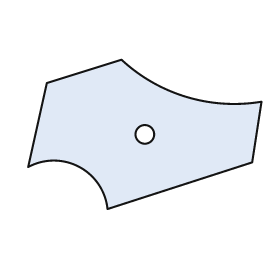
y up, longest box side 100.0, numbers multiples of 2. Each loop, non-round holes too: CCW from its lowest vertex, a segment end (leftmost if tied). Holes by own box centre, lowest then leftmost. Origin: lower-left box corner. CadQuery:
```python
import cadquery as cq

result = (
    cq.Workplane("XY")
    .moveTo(34.0, 0.0)
    .lineTo(96.0, 20.0)
    .lineTo(100.0, 46.0)
    .threePointArc((68.0, 48.0), (40.0, 64.0))
    .lineTo(8.0, 54.0)
    .lineTo(0.0, 18.0)
    .threePointArc((22.0, 18.0), (34.0, 0.0))
    .close()
    .moveTo(50.0, 32.0)
    .circle(4.0)
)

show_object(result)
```